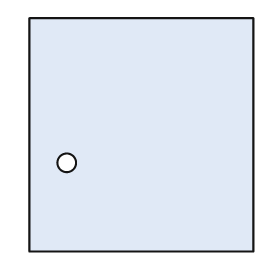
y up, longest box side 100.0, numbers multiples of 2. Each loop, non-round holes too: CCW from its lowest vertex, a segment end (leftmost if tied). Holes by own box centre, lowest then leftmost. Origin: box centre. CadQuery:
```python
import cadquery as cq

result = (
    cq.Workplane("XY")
    .moveTo(-48.0, -50.0)
    .lineTo(48.0, -50.0)
    .lineTo(48.0, 50.0)
    .lineTo(-48.0, 50.0)
    .close()
    .moveTo(-32.0, -12.0)
    .circle(4.0)
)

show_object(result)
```